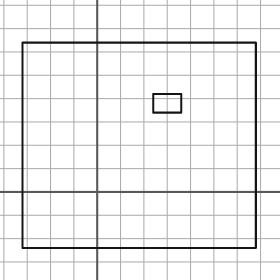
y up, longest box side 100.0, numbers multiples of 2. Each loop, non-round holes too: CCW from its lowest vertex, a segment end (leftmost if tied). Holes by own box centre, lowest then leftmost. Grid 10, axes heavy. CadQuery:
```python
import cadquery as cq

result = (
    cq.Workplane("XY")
    .moveTo(-32.0, -24.0)
    .lineTo(68.0, -24.0)
    .lineTo(68.0, 64.0)
    .lineTo(-32.0, 64.0)
    .close()
    .moveTo(24.0, 34.0)
    .lineTo(36.0, 34.0)
    .lineTo(36.0, 42.0)
    .lineTo(24.0, 42.0)
    .close()
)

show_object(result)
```